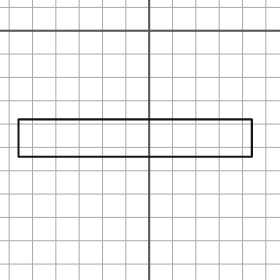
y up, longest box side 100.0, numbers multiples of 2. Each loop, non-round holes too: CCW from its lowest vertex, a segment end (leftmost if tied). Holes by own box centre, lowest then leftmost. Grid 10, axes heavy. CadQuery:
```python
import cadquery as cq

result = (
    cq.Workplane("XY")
    .moveTo(-56.0, -54.0)
    .lineTo(44.0, -54.0)
    .lineTo(44.0, -38.0)
    .lineTo(-56.0, -38.0)
    .close()
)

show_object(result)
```